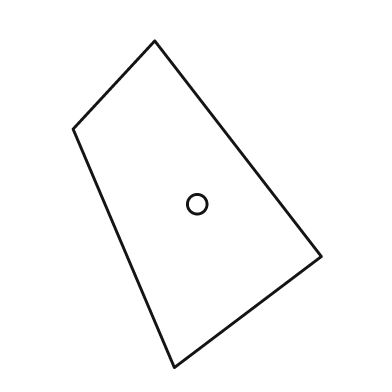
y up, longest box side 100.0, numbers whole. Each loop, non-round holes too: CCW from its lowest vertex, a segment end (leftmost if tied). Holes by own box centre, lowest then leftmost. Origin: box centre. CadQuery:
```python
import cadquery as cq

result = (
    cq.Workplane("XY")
    .moveTo(-7.0, -50.0)
    .lineTo(38.0, -16.0)
    .lineTo(-13.0, 50.0)
    .lineTo(-38.0, 23.0)
    .close()
    .moveTo(0.0, 0.0)
    .circle(3.0)
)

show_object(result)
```